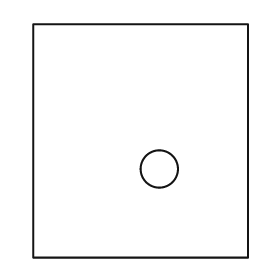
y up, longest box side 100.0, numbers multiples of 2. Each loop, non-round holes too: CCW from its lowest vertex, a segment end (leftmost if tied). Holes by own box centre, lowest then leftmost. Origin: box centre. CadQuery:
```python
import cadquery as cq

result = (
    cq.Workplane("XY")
    .moveTo(-46.0, -50.0)
    .lineTo(46.0, -50.0)
    .lineTo(46.0, 50.0)
    .lineTo(-46.0, 50.0)
    .close()
    .moveTo(8.0, -12.0)
    .circle(8.0)
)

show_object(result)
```